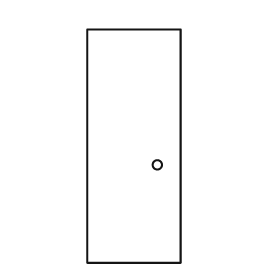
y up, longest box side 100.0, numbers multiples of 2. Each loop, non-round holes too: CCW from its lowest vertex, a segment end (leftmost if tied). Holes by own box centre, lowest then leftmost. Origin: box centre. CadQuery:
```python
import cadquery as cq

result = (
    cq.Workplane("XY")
    .moveTo(-20.0, -50.0)
    .lineTo(20.0, -50.0)
    .lineTo(20.0, 50.0)
    .lineTo(-20.0, 50.0)
    .close()
    .moveTo(10.0, -8.0)
    .circle(2.0)
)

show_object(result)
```